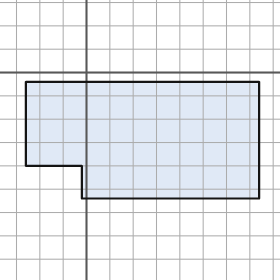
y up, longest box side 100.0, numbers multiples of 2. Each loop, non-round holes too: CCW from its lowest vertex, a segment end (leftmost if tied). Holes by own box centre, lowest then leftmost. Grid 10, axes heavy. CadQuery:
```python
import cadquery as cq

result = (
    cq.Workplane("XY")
    .moveTo(-2.0, -54.0)
    .lineTo(74.0, -54.0)
    .lineTo(74.0, -4.0)
    .lineTo(-26.0, -4.0)
    .lineTo(-26.0, -40.0)
    .lineTo(-2.0, -40.0)
    .close()
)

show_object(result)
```